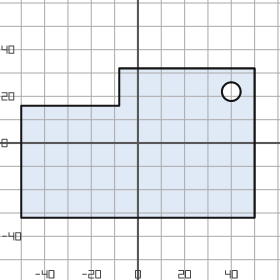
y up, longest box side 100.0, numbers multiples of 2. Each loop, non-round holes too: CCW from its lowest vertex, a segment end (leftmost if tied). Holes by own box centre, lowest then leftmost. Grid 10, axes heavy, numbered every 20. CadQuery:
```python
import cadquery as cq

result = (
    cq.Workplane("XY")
    .moveTo(-50.0, -32.0)
    .lineTo(50.0, -32.0)
    .lineTo(50.0, 32.0)
    .lineTo(-8.0, 32.0)
    .lineTo(-8.0, 16.0)
    .lineTo(-50.0, 16.0)
    .close()
    .moveTo(40.0, 22.0)
    .circle(4.0)
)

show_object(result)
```